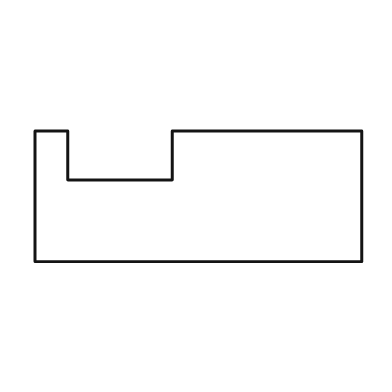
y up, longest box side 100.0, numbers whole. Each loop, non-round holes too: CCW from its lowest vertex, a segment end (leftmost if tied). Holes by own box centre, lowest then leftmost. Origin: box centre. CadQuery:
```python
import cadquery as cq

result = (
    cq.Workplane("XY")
    .moveTo(-50.0, -20.0)
    .lineTo(50.0, -20.0)
    .lineTo(50.0, 20.0)
    .lineTo(-8.0, 20.0)
    .lineTo(-8.0, 5.0)
    .lineTo(-40.0, 5.0)
    .lineTo(-40.0, 20.0)
    .lineTo(-50.0, 20.0)
    .close()
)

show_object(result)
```